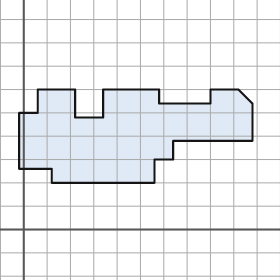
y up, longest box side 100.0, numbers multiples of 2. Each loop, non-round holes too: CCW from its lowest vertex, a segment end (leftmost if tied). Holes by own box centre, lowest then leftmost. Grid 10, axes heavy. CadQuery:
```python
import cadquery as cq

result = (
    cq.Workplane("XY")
    .moveTo(12.0, 20.0)
    .lineTo(56.0, 20.0)
    .lineTo(56.0, 30.0)
    .lineTo(64.0, 30.0)
    .lineTo(64.0, 38.0)
    .lineTo(98.0, 38.0)
    .lineTo(98.0, 54.0)
    .lineTo(92.0, 60.0)
    .lineTo(80.0, 60.0)
    .lineTo(80.0, 54.0)
    .lineTo(58.0, 54.0)
    .lineTo(58.0, 60.0)
    .lineTo(34.0, 60.0)
    .lineTo(34.0, 48.0)
    .lineTo(22.0, 48.0)
    .lineTo(22.0, 60.0)
    .lineTo(6.0, 60.0)
    .lineTo(6.0, 50.0)
    .lineTo(-2.0, 50.0)
    .lineTo(-2.0, 26.0)
    .lineTo(12.0, 26.0)
    .close()
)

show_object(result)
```